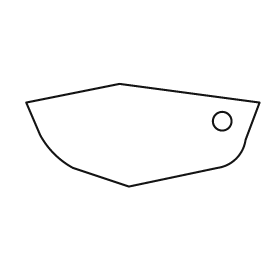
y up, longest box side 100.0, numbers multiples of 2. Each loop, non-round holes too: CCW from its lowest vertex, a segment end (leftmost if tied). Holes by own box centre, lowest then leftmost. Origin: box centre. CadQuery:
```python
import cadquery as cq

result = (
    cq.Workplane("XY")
    .moveTo(-6.0, -22.0)
    .lineTo(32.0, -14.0)
    .threePointArc((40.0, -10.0), (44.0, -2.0))
    .lineTo(50.0, 14.0)
    .lineTo(-10.0, 22.0)
    .lineTo(-50.0, 14.0)
    .lineTo(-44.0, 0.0)
    .threePointArc((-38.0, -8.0), (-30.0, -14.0))
    .close()
    .moveTo(34.0, 6.0)
    .circle(4.0)
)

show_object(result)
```